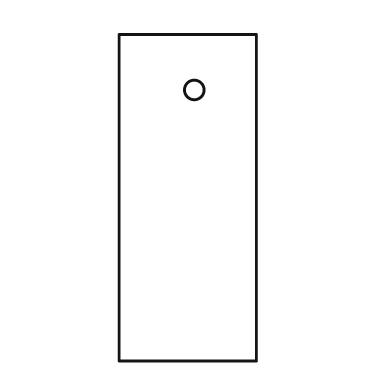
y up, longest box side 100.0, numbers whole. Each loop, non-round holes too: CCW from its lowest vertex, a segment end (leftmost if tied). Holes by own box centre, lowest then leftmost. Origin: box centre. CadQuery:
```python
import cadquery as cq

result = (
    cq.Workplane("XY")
    .moveTo(-21.0, -50.0)
    .lineTo(21.0, -50.0)
    .lineTo(21.0, 50.0)
    .lineTo(-21.0, 50.0)
    .close()
    .moveTo(2.0, 33.0)
    .circle(3.0)
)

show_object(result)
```